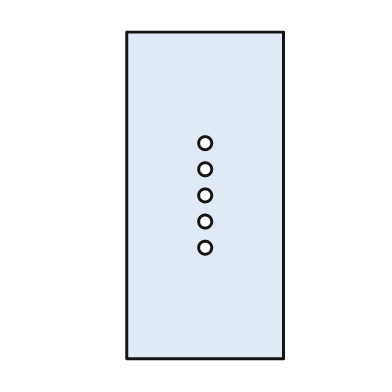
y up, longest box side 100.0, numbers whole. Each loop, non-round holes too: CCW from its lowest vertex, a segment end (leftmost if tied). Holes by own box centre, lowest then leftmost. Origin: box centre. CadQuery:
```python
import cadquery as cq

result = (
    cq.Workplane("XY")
    .moveTo(-24.0, -50.0)
    .lineTo(24.0, -50.0)
    .lineTo(24.0, 50.0)
    .lineTo(-24.0, 50.0)
    .close()
    .moveTo(0.0, -16.0)
    .circle(2.0)
    .moveTo(0.0, -8.0)
    .circle(2.0)
    .moveTo(0.0, 0.0)
    .circle(2.0)
    .moveTo(0.0, 8.0)
    .circle(2.0)
    .moveTo(0.0, 16.0)
    .circle(2.0)
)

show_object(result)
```